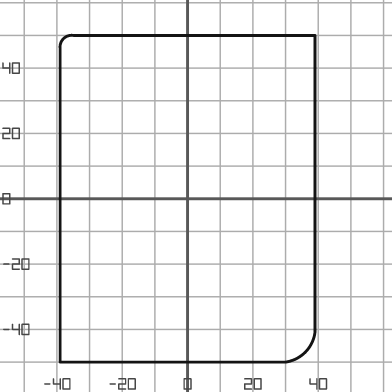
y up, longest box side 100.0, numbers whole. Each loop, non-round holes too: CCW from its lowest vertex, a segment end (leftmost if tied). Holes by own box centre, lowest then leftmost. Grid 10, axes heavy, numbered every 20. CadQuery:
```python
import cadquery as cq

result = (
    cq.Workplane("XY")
    .moveTo(-39.0, -50.0)
    .lineTo(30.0, -50.0)
    .threePointArc((36.0, -47.0), (39.0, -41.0))
    .lineTo(39.0, 50.0)
    .lineTo(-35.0, 50.0)
    .threePointArc((-38.0, 49.0), (-39.0, 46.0))
    .close()
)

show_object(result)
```